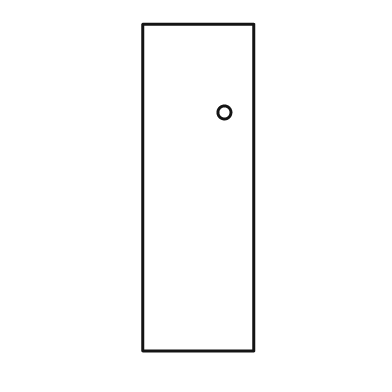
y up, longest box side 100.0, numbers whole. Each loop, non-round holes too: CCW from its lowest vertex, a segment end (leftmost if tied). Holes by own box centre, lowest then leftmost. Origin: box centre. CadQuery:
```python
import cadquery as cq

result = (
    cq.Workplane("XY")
    .moveTo(-17.0, -50.0)
    .lineTo(17.0, -50.0)
    .lineTo(17.0, 50.0)
    .lineTo(-17.0, 50.0)
    .close()
    .moveTo(8.0, 23.0)
    .circle(2.0)
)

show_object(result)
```